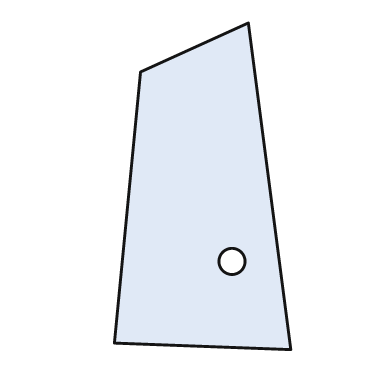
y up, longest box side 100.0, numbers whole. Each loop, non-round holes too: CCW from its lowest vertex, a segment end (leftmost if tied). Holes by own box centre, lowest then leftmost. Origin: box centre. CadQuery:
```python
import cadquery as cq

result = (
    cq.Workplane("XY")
    .moveTo(27.0, -50.0)
    .lineTo(14.0, 50.0)
    .lineTo(-19.0, 35.0)
    .lineTo(-27.0, -48.0)
    .close()
    .moveTo(9.0, -23.0)
    .circle(4.0)
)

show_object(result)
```